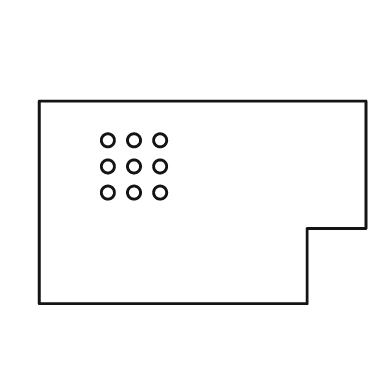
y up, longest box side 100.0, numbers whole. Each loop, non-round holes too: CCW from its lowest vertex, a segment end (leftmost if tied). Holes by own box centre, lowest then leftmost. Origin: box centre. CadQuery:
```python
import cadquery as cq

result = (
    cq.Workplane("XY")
    .moveTo(-50.0, -31.0)
    .lineTo(32.0, -31.0)
    .lineTo(32.0, -8.0)
    .lineTo(50.0, -8.0)
    .lineTo(50.0, 31.0)
    .lineTo(-50.0, 31.0)
    .close()
    .moveTo(-29.0, 3.0)
    .circle(2.0)
    .moveTo(-21.0, 3.0)
    .circle(2.0)
    .moveTo(-13.0, 3.0)
    .circle(2.0)
    .moveTo(-29.0, 11.0)
    .circle(2.0)
    .moveTo(-21.0, 11.0)
    .circle(2.0)
    .moveTo(-13.0, 11.0)
    .circle(2.0)
    .moveTo(-29.0, 19.0)
    .circle(2.0)
    .moveTo(-21.0, 19.0)
    .circle(2.0)
    .moveTo(-13.0, 19.0)
    .circle(2.0)
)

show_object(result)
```